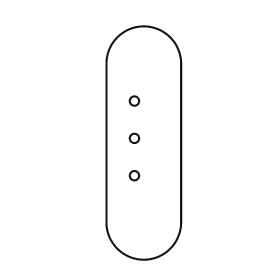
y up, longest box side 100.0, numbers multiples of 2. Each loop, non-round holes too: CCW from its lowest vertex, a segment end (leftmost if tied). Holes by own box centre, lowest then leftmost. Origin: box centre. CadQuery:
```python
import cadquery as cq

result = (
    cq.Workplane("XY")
    .moveTo(-16.0, -34.0)
    .threePointArc((0.0, -50.0), (16.0, -34.0))
    .lineTo(16.0, 34.0)
    .threePointArc((0.0, 50.0), (-16.0, 34.0))
    .close()
    .moveTo(-4.0, -14.0)
    .circle(2.0)
    .moveTo(-4.0, 2.0)
    .circle(2.0)
    .moveTo(-4.0, 18.0)
    .circle(2.0)
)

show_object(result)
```